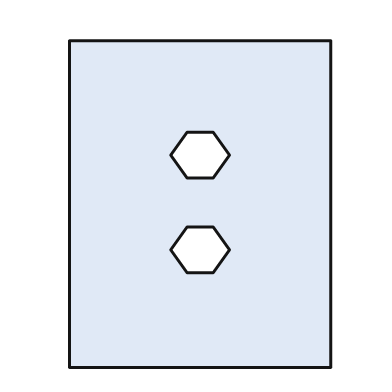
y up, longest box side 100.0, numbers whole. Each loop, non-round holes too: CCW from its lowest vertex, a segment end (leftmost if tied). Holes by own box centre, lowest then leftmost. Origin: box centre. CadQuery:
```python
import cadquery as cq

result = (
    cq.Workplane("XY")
    .moveTo(-40.0, -50.0)
    .lineTo(40.0, -50.0)
    .lineTo(40.0, 50.0)
    .lineTo(-40.0, 50.0)
    .close()
    .moveTo(-4.0, -21.0)
    .lineTo(4.0, -21.0)
    .lineTo(9.0, -14.0)
    .lineTo(4.0, -7.0)
    .lineTo(-4.0, -7.0)
    .lineTo(-9.0, -14.0)
    .close()
    .moveTo(-4.0, 8.0)
    .lineTo(4.0, 8.0)
    .lineTo(9.0, 15.0)
    .lineTo(4.0, 22.0)
    .lineTo(-4.0, 22.0)
    .lineTo(-9.0, 15.0)
    .close()
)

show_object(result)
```